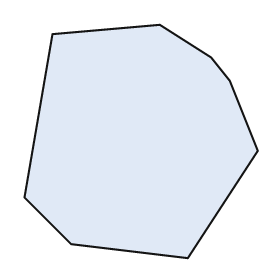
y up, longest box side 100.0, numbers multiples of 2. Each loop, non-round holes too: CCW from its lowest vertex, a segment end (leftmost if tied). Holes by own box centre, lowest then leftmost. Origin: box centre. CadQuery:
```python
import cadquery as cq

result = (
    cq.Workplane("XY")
    .moveTo(20.0, -50.0)
    .lineTo(50.0, -4.0)
    .lineTo(38.0, 26.0)
    .lineTo(30.0, 36.0)
    .lineTo(8.0, 50.0)
    .lineTo(-38.0, 46.0)
    .lineTo(-50.0, -24.0)
    .lineTo(-30.0, -44.0)
    .close()
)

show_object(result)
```